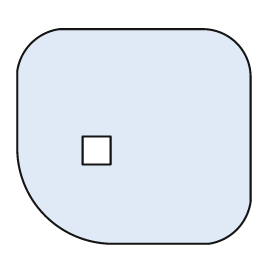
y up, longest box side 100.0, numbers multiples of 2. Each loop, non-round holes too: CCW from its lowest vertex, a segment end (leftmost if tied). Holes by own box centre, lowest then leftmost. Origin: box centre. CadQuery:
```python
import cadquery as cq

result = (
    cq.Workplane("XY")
    .moveTo(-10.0, -46.0)
    .lineTo(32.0, -46.0)
    .threePointArc((44.0, -40.0), (50.0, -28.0))
    .lineTo(50.0, 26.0)
    .threePointArc((44.0, 40.0), (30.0, 46.0))
    .lineTo(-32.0, 46.0)
    .threePointArc((-44.0, 40.0), (-50.0, 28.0))
    .lineTo(-50.0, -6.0)
    .threePointArc((-38.0, -34.0), (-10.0, -46.0))
    .close()
    .moveTo(-22.0, -12.0)
    .lineTo(-10.0, -12.0)
    .lineTo(-10.0, 0.0)
    .lineTo(-22.0, 0.0)
    .close()
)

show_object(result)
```